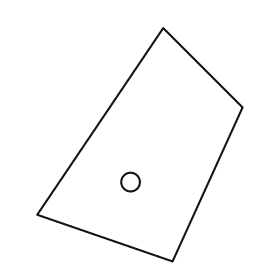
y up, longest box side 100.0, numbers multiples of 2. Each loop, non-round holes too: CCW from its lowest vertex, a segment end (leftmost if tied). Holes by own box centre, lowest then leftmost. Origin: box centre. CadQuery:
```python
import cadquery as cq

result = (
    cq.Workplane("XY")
    .moveTo(14.0, -50.0)
    .lineTo(44.0, 16.0)
    .lineTo(10.0, 50.0)
    .lineTo(-44.0, -30.0)
    .close()
    .moveTo(-4.0, -16.0)
    .circle(4.0)
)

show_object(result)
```